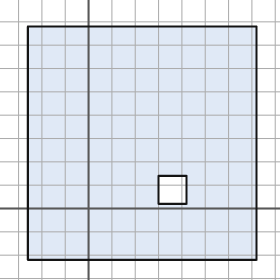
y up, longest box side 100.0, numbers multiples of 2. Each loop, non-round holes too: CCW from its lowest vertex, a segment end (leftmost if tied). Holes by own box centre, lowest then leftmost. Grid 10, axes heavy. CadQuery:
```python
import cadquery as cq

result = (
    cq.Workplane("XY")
    .moveTo(-26.0, -22.0)
    .lineTo(72.0, -22.0)
    .lineTo(72.0, 78.0)
    .lineTo(-26.0, 78.0)
    .close()
    .moveTo(30.0, 2.0)
    .lineTo(42.0, 2.0)
    .lineTo(42.0, 14.0)
    .lineTo(30.0, 14.0)
    .close()
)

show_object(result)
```